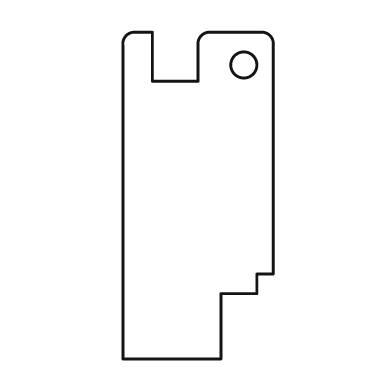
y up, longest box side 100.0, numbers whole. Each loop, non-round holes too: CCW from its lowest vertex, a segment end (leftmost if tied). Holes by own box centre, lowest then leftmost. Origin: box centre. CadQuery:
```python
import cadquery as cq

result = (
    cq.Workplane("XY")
    .moveTo(-23.0, -50.0)
    .lineTo(7.0, -50.0)
    .lineTo(7.0, -30.0)
    .lineTo(18.0, -30.0)
    .lineTo(18.0, -24.0)
    .lineTo(23.0, -24.0)
    .lineTo(23.0, 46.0)
    .threePointArc((22.0, 49.0), (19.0, 50.0))
    .lineTo(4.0, 50.0)
    .threePointArc((1.0, 49.0), (0.0, 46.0))
    .lineTo(0.0, 35.0)
    .lineTo(-14.0, 35.0)
    .lineTo(-14.0, 50.0)
    .lineTo(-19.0, 50.0)
    .threePointArc((-22.0, 49.0), (-23.0, 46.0))
    .close()
    .moveTo(14.0, 40.0)
    .circle(4.0)
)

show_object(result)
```